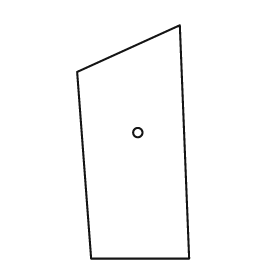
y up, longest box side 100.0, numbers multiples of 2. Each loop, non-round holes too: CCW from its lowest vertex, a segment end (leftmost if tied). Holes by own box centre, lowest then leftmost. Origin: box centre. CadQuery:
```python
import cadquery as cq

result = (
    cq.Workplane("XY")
    .moveTo(-18.0, -50.0)
    .lineTo(24.0, -50.0)
    .lineTo(20.0, 50.0)
    .lineTo(-24.0, 30.0)
    .close()
    .moveTo(2.0, 4.0)
    .circle(2.0)
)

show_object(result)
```